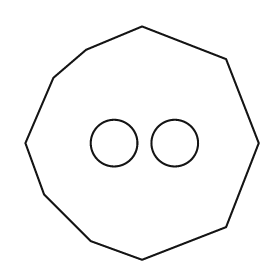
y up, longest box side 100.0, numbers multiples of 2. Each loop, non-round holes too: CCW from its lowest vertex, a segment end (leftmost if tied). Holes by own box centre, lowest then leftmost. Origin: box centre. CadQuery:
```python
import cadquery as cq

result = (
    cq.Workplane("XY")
    .moveTo(0.0, -50.0)
    .lineTo(36.0, -36.0)
    .lineTo(50.0, 0.0)
    .lineTo(36.0, 36.0)
    .lineTo(0.0, 50.0)
    .lineTo(-24.0, 40.0)
    .lineTo(-38.0, 28.0)
    .lineTo(-50.0, 0.0)
    .lineTo(-42.0, -22.0)
    .lineTo(-22.0, -42.0)
    .close()
    .moveTo(-12.0, 0.0)
    .circle(10.0)
    .moveTo(14.0, 0.0)
    .circle(10.0)
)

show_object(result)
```